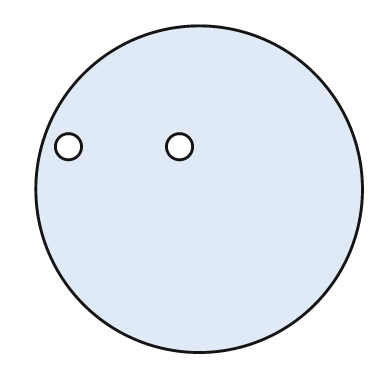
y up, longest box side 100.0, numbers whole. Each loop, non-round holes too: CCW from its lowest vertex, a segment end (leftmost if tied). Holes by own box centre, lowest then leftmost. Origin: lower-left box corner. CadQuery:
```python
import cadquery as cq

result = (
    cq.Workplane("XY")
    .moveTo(50.0, 50.0)
    .circle(50.0)
    .moveTo(10.0, 63.0)
    .circle(4.0)
    .moveTo(44.0, 63.0)
    .circle(4.0)
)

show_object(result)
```